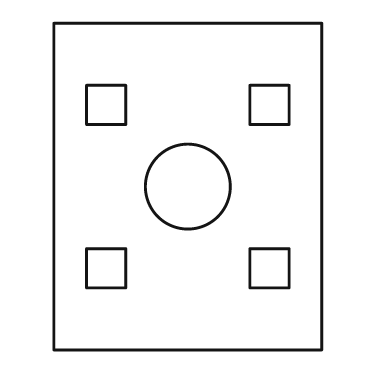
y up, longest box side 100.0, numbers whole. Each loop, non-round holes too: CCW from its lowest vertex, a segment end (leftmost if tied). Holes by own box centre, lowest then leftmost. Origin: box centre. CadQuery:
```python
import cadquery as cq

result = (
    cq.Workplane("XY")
    .moveTo(-41.0, -50.0)
    .lineTo(41.0, -50.0)
    .lineTo(41.0, 50.0)
    .lineTo(-41.0, 50.0)
    .close()
    .moveTo(-31.0, -31.0)
    .lineTo(-19.0, -31.0)
    .lineTo(-19.0, -19.0)
    .lineTo(-31.0, -19.0)
    .close()
    .moveTo(19.0, -31.0)
    .lineTo(31.0, -31.0)
    .lineTo(31.0, -19.0)
    .lineTo(19.0, -19.0)
    .close()
    .moveTo(0.0, 0.0)
    .circle(13.0)
    .moveTo(-31.0, 19.0)
    .lineTo(-19.0, 19.0)
    .lineTo(-19.0, 31.0)
    .lineTo(-31.0, 31.0)
    .close()
    .moveTo(19.0, 19.0)
    .lineTo(31.0, 19.0)
    .lineTo(31.0, 31.0)
    .lineTo(19.0, 31.0)
    .close()
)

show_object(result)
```